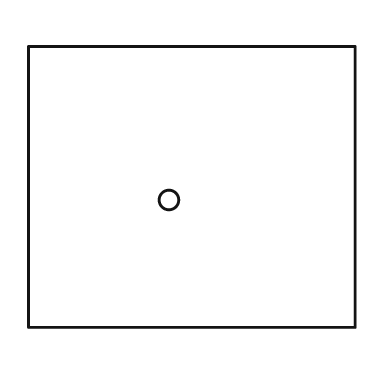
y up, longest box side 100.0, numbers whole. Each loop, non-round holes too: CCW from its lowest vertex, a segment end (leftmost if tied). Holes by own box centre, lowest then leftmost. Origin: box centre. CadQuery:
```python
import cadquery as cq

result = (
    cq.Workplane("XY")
    .moveTo(-50.0, -43.0)
    .lineTo(50.0, -43.0)
    .lineTo(50.0, 43.0)
    .lineTo(-50.0, 43.0)
    .close()
    .moveTo(-7.0, -4.0)
    .circle(3.0)
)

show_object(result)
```